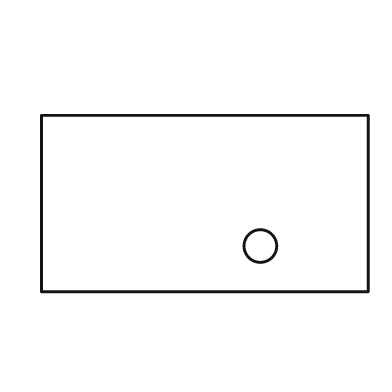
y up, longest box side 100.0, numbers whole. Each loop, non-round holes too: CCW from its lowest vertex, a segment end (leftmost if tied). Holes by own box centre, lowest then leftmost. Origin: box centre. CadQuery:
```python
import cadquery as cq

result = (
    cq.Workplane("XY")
    .moveTo(-50.0, -27.0)
    .lineTo(50.0, -27.0)
    .lineTo(50.0, 27.0)
    .lineTo(-50.0, 27.0)
    .close()
    .moveTo(17.0, -13.0)
    .circle(5.0)
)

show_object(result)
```